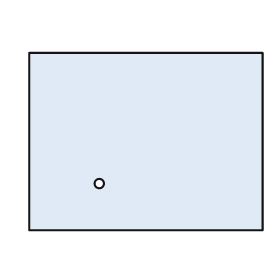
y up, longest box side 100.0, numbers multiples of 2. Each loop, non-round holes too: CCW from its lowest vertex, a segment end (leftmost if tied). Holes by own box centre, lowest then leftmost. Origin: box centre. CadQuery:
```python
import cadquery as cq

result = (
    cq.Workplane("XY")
    .moveTo(-50.0, -38.0)
    .lineTo(50.0, -38.0)
    .lineTo(50.0, 38.0)
    .lineTo(-50.0, 38.0)
    .close()
    .moveTo(-20.0, -18.0)
    .circle(2.0)
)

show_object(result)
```